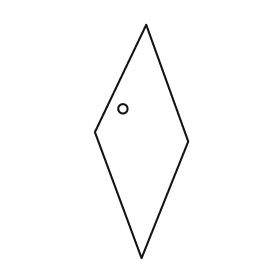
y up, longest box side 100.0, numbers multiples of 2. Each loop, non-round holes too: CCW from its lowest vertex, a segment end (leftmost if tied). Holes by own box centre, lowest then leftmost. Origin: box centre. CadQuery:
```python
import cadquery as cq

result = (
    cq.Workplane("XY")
    .moveTo(0.0, -50.0)
    .lineTo(20.0, 0.0)
    .lineTo(2.0, 50.0)
    .lineTo(-20.0, 4.0)
    .close()
    .moveTo(-8.0, 14.0)
    .circle(2.0)
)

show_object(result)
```